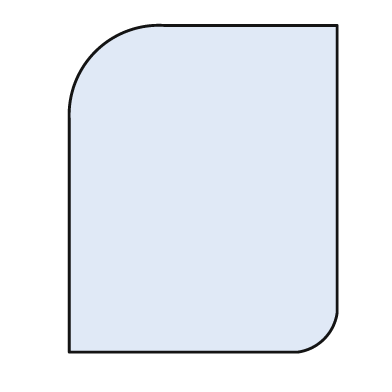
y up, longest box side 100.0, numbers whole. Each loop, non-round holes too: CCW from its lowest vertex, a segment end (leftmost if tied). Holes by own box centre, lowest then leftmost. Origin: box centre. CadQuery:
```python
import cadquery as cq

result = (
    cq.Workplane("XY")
    .moveTo(-41.0, -50.0)
    .lineTo(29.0, -50.0)
    .threePointArc((37.0, -46.0), (41.0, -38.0))
    .lineTo(41.0, 50.0)
    .lineTo(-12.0, 50.0)
    .threePointArc((-33.0, 42.0), (-41.0, 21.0))
    .close()
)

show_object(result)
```